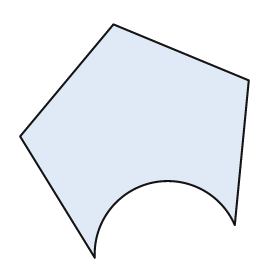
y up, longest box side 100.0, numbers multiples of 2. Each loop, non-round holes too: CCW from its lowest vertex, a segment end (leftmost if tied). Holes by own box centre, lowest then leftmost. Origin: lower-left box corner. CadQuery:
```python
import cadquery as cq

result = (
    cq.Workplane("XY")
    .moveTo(32.0, 0.0)
    .threePointArc((56.0, 32.0), (92.0, 14.0))
    .lineTo(98.0, 76.0)
    .lineTo(40.0, 100.0)
    .lineTo(0.0, 52.0)
    .close()
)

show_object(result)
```